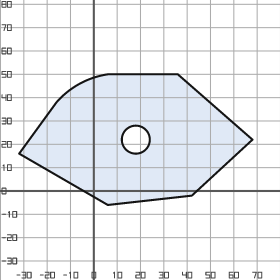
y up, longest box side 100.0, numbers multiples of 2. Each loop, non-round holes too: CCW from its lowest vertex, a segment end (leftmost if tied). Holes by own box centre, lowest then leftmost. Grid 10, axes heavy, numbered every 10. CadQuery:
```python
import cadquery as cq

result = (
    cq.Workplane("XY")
    .moveTo(6.0, -6.0)
    .lineTo(42.0, -2.0)
    .lineTo(68.0, 22.0)
    .lineTo(36.0, 50.0)
    .lineTo(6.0, 50.0)
    .threePointArc((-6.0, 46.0), (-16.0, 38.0))
    .lineTo(-32.0, 16.0)
    .close()
    .moveTo(18.0, 22.0)
    .circle(6.0)
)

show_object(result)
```